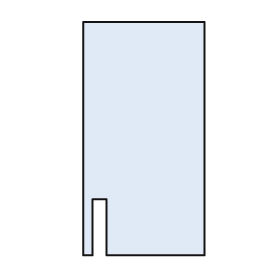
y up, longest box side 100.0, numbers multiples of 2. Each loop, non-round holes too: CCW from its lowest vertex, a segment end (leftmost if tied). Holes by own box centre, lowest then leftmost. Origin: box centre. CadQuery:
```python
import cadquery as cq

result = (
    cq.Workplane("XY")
    .moveTo(-26.0, -50.0)
    .lineTo(-22.0, -50.0)
    .lineTo(-22.0, -26.0)
    .lineTo(-16.0, -26.0)
    .lineTo(-16.0, -50.0)
    .lineTo(26.0, -50.0)
    .lineTo(26.0, 50.0)
    .lineTo(-26.0, 50.0)
    .close()
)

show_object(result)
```